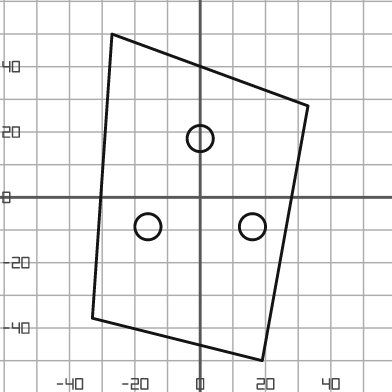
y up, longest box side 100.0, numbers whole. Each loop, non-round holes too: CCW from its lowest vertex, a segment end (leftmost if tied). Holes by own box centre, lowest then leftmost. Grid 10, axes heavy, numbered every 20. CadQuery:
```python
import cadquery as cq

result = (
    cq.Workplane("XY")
    .moveTo(19.0, -50.0)
    .lineTo(33.0, 28.0)
    .lineTo(-27.0, 50.0)
    .lineTo(-33.0, -37.0)
    .close()
    .moveTo(-16.0, -9.0)
    .circle(4.0)
    .moveTo(16.0, -9.0)
    .circle(4.0)
    .moveTo(0.0, 18.0)
    .circle(4.0)
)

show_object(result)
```